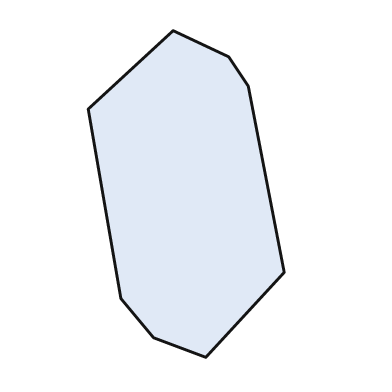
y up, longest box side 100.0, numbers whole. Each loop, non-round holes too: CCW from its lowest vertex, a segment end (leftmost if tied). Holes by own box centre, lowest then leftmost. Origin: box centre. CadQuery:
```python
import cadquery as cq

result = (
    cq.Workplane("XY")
    .moveTo(6.0, -50.0)
    .lineTo(30.0, -24.0)
    .lineTo(19.0, 33.0)
    .lineTo(13.0, 42.0)
    .lineTo(-4.0, 50.0)
    .lineTo(-30.0, 26.0)
    .lineTo(-20.0, -32.0)
    .lineTo(-10.0, -44.0)
    .close()
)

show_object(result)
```